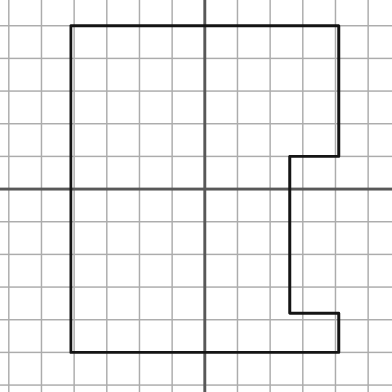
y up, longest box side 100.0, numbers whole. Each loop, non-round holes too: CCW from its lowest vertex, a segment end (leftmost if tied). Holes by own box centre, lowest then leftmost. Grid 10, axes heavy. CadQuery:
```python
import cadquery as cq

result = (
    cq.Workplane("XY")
    .moveTo(-41.0, -50.0)
    .lineTo(41.0, -50.0)
    .lineTo(41.0, -38.0)
    .lineTo(26.0, -38.0)
    .lineTo(26.0, 10.0)
    .lineTo(41.0, 10.0)
    .lineTo(41.0, 50.0)
    .lineTo(-41.0, 50.0)
    .close()
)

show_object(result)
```